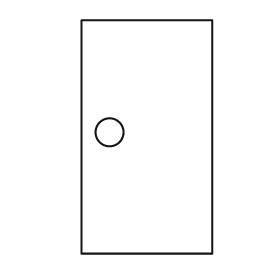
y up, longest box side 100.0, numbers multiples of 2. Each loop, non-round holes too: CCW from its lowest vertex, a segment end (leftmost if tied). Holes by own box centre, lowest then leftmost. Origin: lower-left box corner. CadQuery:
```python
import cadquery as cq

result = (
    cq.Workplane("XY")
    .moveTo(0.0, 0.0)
    .lineTo(56.0, 0.0)
    .lineTo(56.0, 100.0)
    .lineTo(0.0, 100.0)
    .close()
    .moveTo(12.0, 52.0)
    .circle(6.0)
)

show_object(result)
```